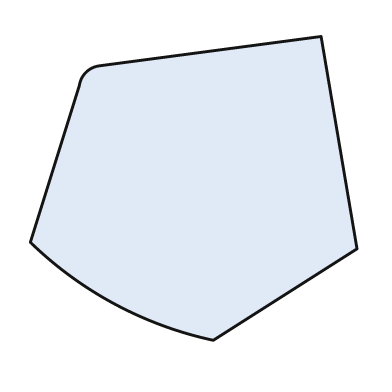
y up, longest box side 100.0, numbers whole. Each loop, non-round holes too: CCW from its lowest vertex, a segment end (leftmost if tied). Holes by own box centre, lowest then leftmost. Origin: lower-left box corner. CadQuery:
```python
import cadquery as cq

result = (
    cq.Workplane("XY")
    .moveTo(56.0, 0.0)
    .lineTo(100.0, 28.0)
    .lineTo(89.0, 93.0)
    .lineTo(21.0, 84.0)
    .threePointArc((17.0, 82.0), (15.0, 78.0))
    .lineTo(0.0, 30.0)
    .threePointArc((26.0, 11.0), (56.0, 0.0))
    .close()
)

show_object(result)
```